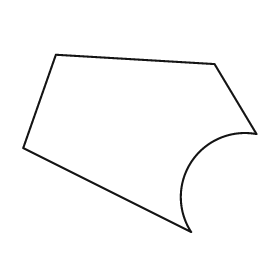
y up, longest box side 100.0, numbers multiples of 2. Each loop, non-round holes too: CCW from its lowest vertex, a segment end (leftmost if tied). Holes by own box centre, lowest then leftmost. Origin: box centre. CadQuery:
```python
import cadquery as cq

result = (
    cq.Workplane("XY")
    .moveTo(22.0, -38.0)
    .threePointArc((22.0, -8.0), (50.0, 4.0))
    .lineTo(32.0, 34.0)
    .lineTo(-36.0, 38.0)
    .lineTo(-50.0, -2.0)
    .close()
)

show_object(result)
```